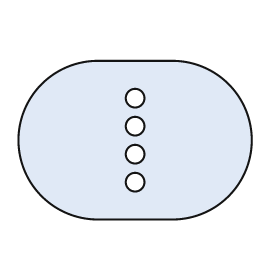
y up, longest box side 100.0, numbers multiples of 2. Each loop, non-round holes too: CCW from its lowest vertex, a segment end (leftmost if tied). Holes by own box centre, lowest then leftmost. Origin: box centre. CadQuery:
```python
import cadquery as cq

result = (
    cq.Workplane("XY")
    .moveTo(-16.0, -34.0)
    .lineTo(16.0, -34.0)
    .threePointArc((50.0, 0.0), (16.0, 34.0))
    .lineTo(-16.0, 34.0)
    .threePointArc((-50.0, 0.0), (-16.0, -34.0))
    .close()
    .moveTo(0.0, -18.0)
    .circle(4.0)
    .moveTo(0.0, -6.0)
    .circle(4.0)
    .moveTo(0.0, 6.0)
    .circle(4.0)
    .moveTo(0.0, 18.0)
    .circle(4.0)
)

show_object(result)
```